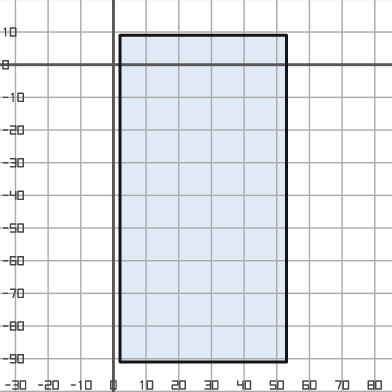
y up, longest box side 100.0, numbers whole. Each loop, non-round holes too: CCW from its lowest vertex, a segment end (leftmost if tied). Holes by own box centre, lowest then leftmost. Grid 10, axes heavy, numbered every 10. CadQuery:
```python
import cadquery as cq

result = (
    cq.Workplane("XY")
    .moveTo(2.0, -91.0)
    .lineTo(53.0, -91.0)
    .lineTo(53.0, 9.0)
    .lineTo(2.0, 9.0)
    .close()
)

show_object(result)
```